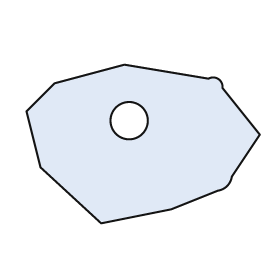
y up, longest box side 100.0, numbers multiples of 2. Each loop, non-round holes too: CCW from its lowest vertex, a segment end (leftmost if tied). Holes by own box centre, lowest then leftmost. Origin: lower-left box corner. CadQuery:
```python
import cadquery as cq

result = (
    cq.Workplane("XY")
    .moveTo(32.0, 0.0)
    .lineTo(62.0, 6.0)
    .lineTo(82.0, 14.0)
    .threePointArc((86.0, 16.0), (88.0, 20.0))
    .lineTo(100.0, 38.0)
    .lineTo(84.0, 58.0)
    .threePointArc((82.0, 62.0), (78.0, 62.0))
    .lineTo(42.0, 68.0)
    .lineTo(12.0, 60.0)
    .lineTo(0.0, 48.0)
    .lineTo(6.0, 24.0)
    .close()
    .moveTo(44.0, 44.0)
    .circle(8.0)
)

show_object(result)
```